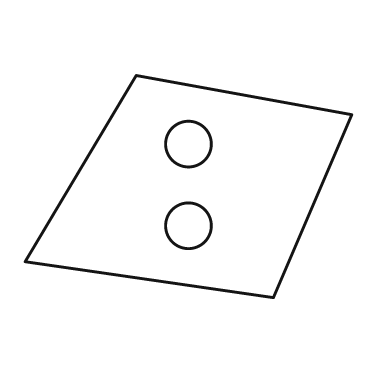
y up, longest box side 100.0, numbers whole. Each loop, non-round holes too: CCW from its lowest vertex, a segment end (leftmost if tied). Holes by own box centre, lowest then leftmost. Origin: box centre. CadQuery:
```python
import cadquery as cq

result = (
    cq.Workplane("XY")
    .moveTo(26.0, -34.0)
    .lineTo(50.0, 22.0)
    .lineTo(-16.0, 34.0)
    .lineTo(-50.0, -23.0)
    .close()
    .moveTo(0.0, -12.0)
    .circle(7.0)
    .moveTo(0.0, 13.0)
    .circle(7.0)
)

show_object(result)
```